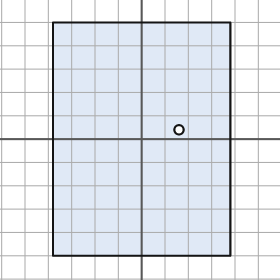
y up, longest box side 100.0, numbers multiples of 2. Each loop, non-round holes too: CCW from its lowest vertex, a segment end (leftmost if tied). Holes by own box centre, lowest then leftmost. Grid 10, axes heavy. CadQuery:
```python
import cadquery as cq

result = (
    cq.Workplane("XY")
    .moveTo(-38.0, -50.0)
    .lineTo(38.0, -50.0)
    .lineTo(38.0, 50.0)
    .lineTo(-38.0, 50.0)
    .close()
    .moveTo(16.0, 4.0)
    .circle(2.0)
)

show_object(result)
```